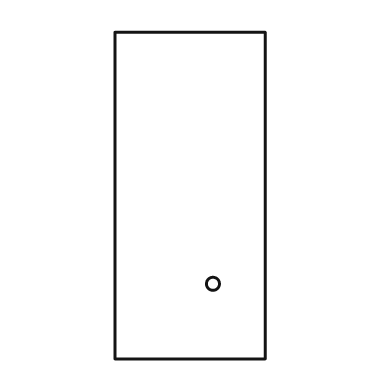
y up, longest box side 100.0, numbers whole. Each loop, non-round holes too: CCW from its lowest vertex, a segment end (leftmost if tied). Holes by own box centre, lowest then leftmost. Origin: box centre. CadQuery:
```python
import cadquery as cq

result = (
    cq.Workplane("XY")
    .moveTo(-23.0, -50.0)
    .lineTo(23.0, -50.0)
    .lineTo(23.0, 50.0)
    .lineTo(-23.0, 50.0)
    .close()
    .moveTo(7.0, -27.0)
    .circle(2.0)
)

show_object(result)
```